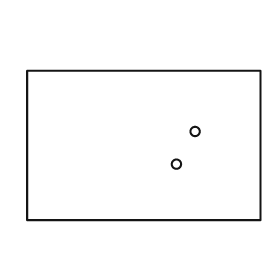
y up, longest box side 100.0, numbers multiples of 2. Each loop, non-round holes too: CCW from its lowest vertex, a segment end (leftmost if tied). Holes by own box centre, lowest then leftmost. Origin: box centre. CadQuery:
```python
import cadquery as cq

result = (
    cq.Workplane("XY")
    .moveTo(-50.0, -32.0)
    .lineTo(50.0, -32.0)
    .lineTo(50.0, 32.0)
    .lineTo(-50.0, 32.0)
    .close()
    .moveTo(14.0, -8.0)
    .circle(2.0)
    .moveTo(22.0, 6.0)
    .circle(2.0)
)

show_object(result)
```